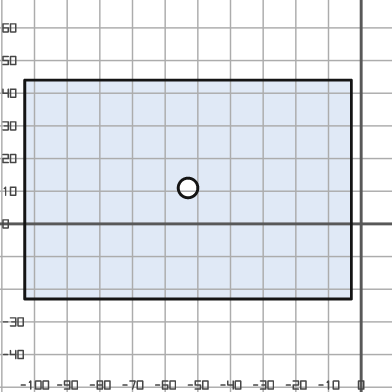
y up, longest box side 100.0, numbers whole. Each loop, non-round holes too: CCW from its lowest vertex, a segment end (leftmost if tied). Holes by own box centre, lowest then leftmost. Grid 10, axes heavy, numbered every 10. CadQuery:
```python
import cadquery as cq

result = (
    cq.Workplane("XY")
    .moveTo(-103.0, -23.0)
    .lineTo(-3.0, -23.0)
    .lineTo(-3.0, 44.0)
    .lineTo(-103.0, 44.0)
    .close()
    .moveTo(-53.0, 11.0)
    .circle(3.0)
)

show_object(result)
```